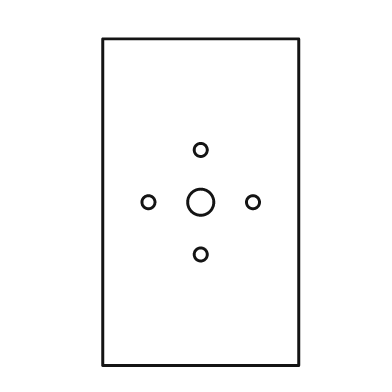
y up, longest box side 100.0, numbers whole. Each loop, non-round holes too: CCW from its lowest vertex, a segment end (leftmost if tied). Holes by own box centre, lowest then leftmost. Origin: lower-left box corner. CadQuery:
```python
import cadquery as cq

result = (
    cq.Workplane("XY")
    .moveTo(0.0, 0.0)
    .lineTo(60.0, 0.0)
    .lineTo(60.0, 100.0)
    .lineTo(0.0, 100.0)
    .close()
    .moveTo(30.0, 34.0)
    .circle(2.0)
    .moveTo(14.0, 50.0)
    .circle(2.0)
    .moveTo(30.0, 50.0)
    .circle(4.0)
    .moveTo(46.0, 50.0)
    .circle(2.0)
    .moveTo(30.0, 66.0)
    .circle(2.0)
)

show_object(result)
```